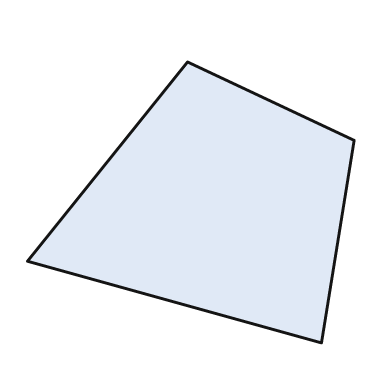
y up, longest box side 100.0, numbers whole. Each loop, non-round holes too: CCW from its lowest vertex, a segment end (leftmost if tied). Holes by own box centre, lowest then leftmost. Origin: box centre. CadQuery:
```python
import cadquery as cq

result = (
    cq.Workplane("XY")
    .moveTo(40.0, -43.0)
    .lineTo(50.0, 19.0)
    .lineTo(-1.0, 43.0)
    .lineTo(-50.0, -18.0)
    .close()
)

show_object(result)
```